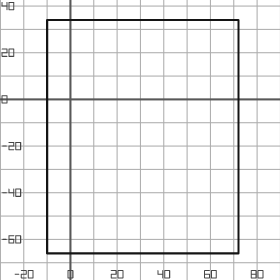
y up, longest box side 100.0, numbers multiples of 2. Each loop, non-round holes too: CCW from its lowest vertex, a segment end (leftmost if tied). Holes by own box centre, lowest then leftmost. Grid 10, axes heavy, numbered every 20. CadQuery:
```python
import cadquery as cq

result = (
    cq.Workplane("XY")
    .moveTo(-10.0, -66.0)
    .lineTo(72.0, -66.0)
    .lineTo(72.0, 34.0)
    .lineTo(-10.0, 34.0)
    .close()
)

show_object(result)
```